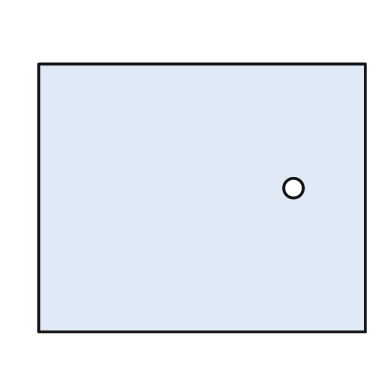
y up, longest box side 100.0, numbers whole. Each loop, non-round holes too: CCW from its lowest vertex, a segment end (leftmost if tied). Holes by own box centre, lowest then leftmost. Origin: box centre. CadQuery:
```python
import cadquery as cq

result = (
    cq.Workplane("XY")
    .moveTo(-50.0, -41.0)
    .lineTo(50.0, -41.0)
    .lineTo(50.0, 41.0)
    .lineTo(-50.0, 41.0)
    .close()
    .moveTo(28.0, 3.0)
    .circle(3.0)
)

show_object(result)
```